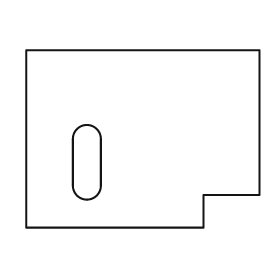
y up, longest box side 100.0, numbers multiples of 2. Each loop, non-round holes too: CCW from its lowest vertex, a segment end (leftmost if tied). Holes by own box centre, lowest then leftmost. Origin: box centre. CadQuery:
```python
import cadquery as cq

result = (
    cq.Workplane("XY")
    .moveTo(-50.0, -38.0)
    .lineTo(26.0, -38.0)
    .lineTo(26.0, -24.0)
    .lineTo(50.0, -24.0)
    .lineTo(50.0, 38.0)
    .lineTo(-50.0, 38.0)
    .close()
    .moveTo(-30.0, -20.0)
    .threePointArc((-24.0, -26.0), (-18.0, -20.0))
    .lineTo(-18.0, 0.0)
    .threePointArc((-24.0, 6.0), (-30.0, 0.0))
    .close()
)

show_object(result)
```